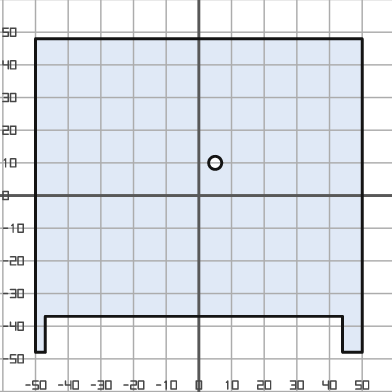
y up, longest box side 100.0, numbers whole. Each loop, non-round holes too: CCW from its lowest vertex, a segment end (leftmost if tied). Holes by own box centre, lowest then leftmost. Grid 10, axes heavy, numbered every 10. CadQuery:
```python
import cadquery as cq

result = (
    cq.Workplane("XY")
    .moveTo(-50.0, -48.0)
    .lineTo(-47.0, -48.0)
    .lineTo(-47.0, -37.0)
    .lineTo(44.0, -37.0)
    .lineTo(44.0, -48.0)
    .lineTo(50.0, -48.0)
    .lineTo(50.0, 48.0)
    .lineTo(-50.0, 48.0)
    .close()
    .moveTo(5.0, 10.0)
    .circle(2.0)
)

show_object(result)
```